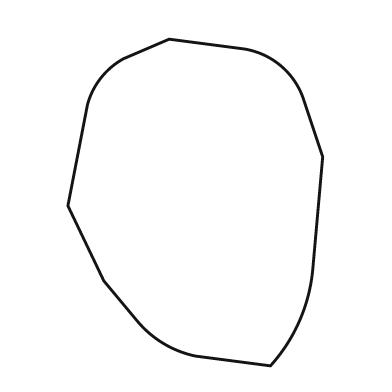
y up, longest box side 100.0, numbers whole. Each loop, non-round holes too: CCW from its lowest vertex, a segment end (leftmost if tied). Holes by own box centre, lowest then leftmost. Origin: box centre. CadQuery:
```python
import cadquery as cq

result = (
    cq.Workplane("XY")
    .moveTo(23.0, -50.0)
    .threePointArc((32.0, -36.0), (36.0, -20.0))
    .lineTo(39.0, 14.0)
    .lineTo(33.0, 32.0)
    .threePointArc((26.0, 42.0), (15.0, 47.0))
    .lineTo(-8.0, 50.0)
    .lineTo(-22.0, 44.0)
    .threePointArc((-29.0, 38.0), (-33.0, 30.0))
    .lineTo(-39.0, -1.0)
    .lineTo(-28.0, -24.0)
    .lineTo(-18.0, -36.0)
    .threePointArc((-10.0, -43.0), (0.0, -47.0))
    .close()
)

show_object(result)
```